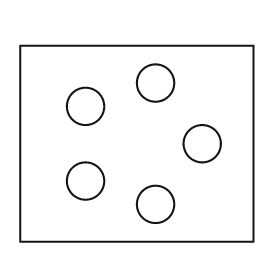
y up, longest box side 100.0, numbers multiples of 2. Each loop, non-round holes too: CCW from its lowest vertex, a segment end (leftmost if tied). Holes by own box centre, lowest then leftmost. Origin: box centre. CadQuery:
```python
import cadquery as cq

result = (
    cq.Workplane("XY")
    .moveTo(-50.0, -42.0)
    .lineTo(50.0, -42.0)
    .lineTo(50.0, 42.0)
    .lineTo(-50.0, 42.0)
    .close()
    .moveTo(8.0, -26.0)
    .circle(8.0)
    .moveTo(-22.0, -16.0)
    .circle(8.0)
    .moveTo(28.0, 0.0)
    .circle(8.0)
    .moveTo(-22.0, 16.0)
    .circle(8.0)
    .moveTo(8.0, 26.0)
    .circle(8.0)
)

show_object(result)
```